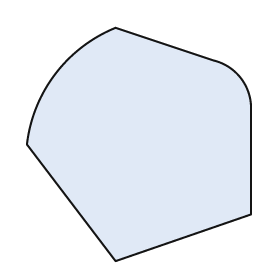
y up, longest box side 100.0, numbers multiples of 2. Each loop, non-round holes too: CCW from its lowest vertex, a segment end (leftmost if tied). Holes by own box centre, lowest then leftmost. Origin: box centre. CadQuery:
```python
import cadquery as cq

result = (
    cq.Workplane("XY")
    .moveTo(-10.0, -50.0)
    .lineTo(48.0, -30.0)
    .lineTo(48.0, 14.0)
    .threePointArc((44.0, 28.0), (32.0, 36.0))
    .lineTo(-10.0, 50.0)
    .threePointArc((-36.0, 30.0), (-48.0, 0.0))
    .close()
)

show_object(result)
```